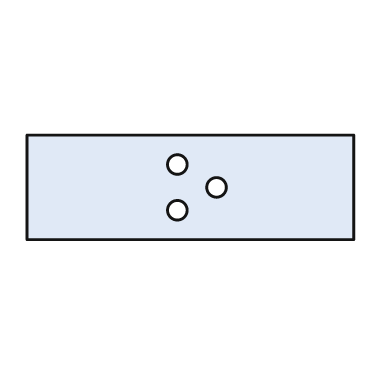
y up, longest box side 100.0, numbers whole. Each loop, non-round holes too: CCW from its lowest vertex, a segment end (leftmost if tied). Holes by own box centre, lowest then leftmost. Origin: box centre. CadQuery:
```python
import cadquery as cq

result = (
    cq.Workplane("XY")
    .moveTo(-50.0, -16.0)
    .lineTo(50.0, -16.0)
    .lineTo(50.0, 16.0)
    .lineTo(-50.0, 16.0)
    .close()
    .moveTo(-4.0, -7.0)
    .circle(3.0)
    .moveTo(8.0, 0.0)
    .circle(3.0)
    .moveTo(-4.0, 7.0)
    .circle(3.0)
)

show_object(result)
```